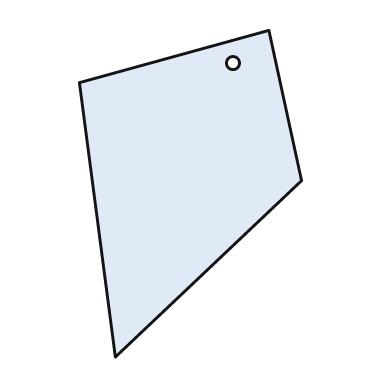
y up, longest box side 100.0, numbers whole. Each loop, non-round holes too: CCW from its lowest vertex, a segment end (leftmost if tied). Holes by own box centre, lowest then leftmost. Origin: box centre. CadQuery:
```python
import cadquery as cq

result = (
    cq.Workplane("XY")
    .moveTo(-23.0, -50.0)
    .lineTo(34.0, 4.0)
    .lineTo(24.0, 50.0)
    .lineTo(-34.0, 34.0)
    .close()
    .moveTo(13.0, 40.0)
    .circle(2.0)
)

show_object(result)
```